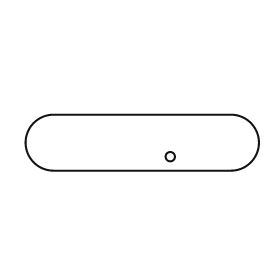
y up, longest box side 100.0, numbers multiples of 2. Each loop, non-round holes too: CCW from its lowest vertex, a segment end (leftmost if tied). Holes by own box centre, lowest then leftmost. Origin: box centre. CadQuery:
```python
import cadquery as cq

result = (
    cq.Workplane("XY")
    .moveTo(-38.0, -12.0)
    .lineTo(38.0, -12.0)
    .threePointArc((50.0, 0.0), (38.0, 12.0))
    .lineTo(-38.0, 12.0)
    .threePointArc((-50.0, 0.0), (-38.0, -12.0))
    .close()
    .moveTo(12.0, -6.0)
    .circle(2.0)
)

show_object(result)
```